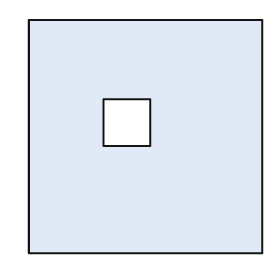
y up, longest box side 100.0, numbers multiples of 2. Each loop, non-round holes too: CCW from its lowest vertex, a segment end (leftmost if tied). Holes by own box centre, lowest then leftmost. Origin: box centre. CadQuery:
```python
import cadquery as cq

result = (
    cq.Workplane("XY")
    .moveTo(-50.0, -50.0)
    .lineTo(50.0, -50.0)
    .lineTo(50.0, 50.0)
    .lineTo(-50.0, 50.0)
    .close()
    .moveTo(-18.0, -4.0)
    .lineTo(2.0, -4.0)
    .lineTo(2.0, 16.0)
    .lineTo(-18.0, 16.0)
    .close()
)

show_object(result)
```